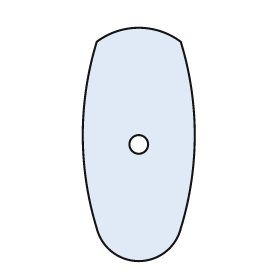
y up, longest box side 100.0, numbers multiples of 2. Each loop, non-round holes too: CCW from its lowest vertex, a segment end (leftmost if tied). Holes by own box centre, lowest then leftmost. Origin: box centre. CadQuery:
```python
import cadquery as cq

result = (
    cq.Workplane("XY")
    .moveTo(-18.0, -36.0)
    .threePointArc((0.0, -50.0), (18.0, -36.0))
    .threePointArc((24.0, 4.0), (18.0, 44.0))
    .threePointArc((0.0, 50.0), (-18.0, 44.0))
    .threePointArc((-24.0, 4.0), (-18.0, -36.0))
    .close()
    .moveTo(0.0, 0.0)
    .circle(4.0)
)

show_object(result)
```